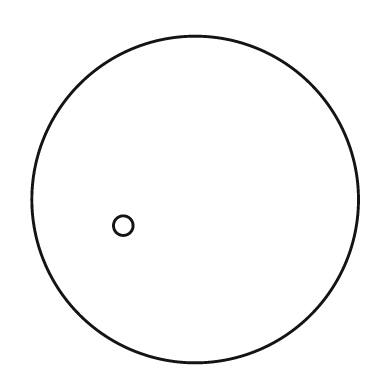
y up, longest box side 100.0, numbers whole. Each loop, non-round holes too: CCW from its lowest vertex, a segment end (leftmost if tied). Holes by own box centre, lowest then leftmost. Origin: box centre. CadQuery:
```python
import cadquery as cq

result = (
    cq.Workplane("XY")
    .moveTo(0.0, 0.0)
    .circle(50.0)
    .moveTo(-22.0, -8.0)
    .circle(3.0)
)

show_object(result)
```